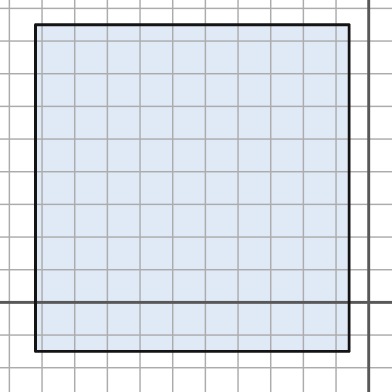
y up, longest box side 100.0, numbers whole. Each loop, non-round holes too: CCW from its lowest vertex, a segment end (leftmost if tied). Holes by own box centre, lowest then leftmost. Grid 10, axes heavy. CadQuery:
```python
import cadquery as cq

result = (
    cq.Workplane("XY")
    .moveTo(-102.0, -15.0)
    .lineTo(-6.0, -15.0)
    .lineTo(-6.0, 85.0)
    .lineTo(-102.0, 85.0)
    .close()
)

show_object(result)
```